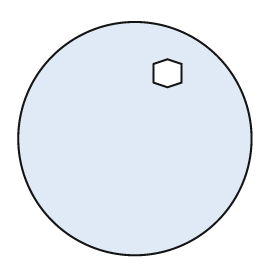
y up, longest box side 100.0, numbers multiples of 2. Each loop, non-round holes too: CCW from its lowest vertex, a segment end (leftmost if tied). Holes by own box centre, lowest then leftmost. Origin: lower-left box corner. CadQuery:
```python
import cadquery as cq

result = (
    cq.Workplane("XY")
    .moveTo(50.0, 50.0)
    .circle(50.0)
    .moveTo(64.0, 72.0)
    .lineTo(70.0, 74.0)
    .lineTo(70.0, 82.0)
    .lineTo(64.0, 84.0)
    .lineTo(58.0, 82.0)
    .lineTo(58.0, 74.0)
    .close()
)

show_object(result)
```